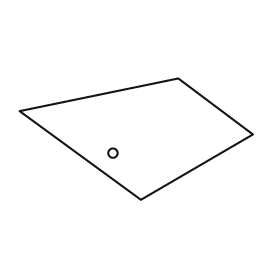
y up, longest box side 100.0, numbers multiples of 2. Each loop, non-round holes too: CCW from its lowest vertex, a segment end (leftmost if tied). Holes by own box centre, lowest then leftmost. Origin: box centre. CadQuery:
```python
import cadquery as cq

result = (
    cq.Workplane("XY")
    .moveTo(2.0, -26.0)
    .lineTo(50.0, 2.0)
    .lineTo(18.0, 26.0)
    .lineTo(-50.0, 12.0)
    .close()
    .moveTo(-10.0, -6.0)
    .circle(2.0)
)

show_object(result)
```